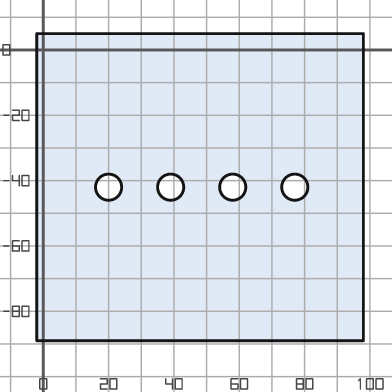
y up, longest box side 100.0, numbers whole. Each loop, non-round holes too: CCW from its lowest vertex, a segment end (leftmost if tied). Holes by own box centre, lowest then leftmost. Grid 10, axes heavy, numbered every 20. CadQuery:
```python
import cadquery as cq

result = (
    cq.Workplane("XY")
    .moveTo(-2.0, -89.0)
    .lineTo(98.0, -89.0)
    .lineTo(98.0, 5.0)
    .lineTo(-2.0, 5.0)
    .close()
    .moveTo(20.0, -42.0)
    .circle(4.0)
    .moveTo(39.0, -42.0)
    .circle(4.0)
    .moveTo(58.0, -42.0)
    .circle(4.0)
    .moveTo(77.0, -42.0)
    .circle(4.0)
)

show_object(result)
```